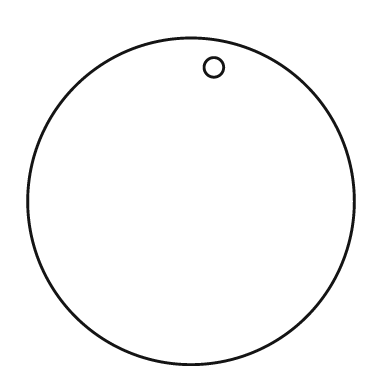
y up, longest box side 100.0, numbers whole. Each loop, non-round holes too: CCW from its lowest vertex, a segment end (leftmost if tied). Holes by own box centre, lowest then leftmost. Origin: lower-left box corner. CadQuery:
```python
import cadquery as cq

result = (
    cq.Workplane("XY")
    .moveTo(50.0, 50.0)
    .circle(50.0)
    .moveTo(57.0, 91.0)
    .circle(3.0)
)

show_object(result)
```